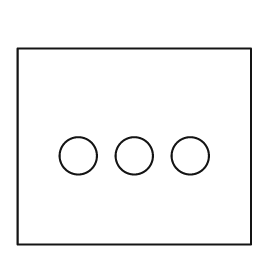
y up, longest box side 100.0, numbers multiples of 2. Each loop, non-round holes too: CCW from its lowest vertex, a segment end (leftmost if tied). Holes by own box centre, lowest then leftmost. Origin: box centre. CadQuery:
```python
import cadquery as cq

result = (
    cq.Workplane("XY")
    .moveTo(-50.0, -42.0)
    .lineTo(50.0, -42.0)
    .lineTo(50.0, 42.0)
    .lineTo(-50.0, 42.0)
    .close()
    .moveTo(-24.0, -4.0)
    .circle(8.0)
    .moveTo(0.0, -4.0)
    .circle(8.0)
    .moveTo(24.0, -4.0)
    .circle(8.0)
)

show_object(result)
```